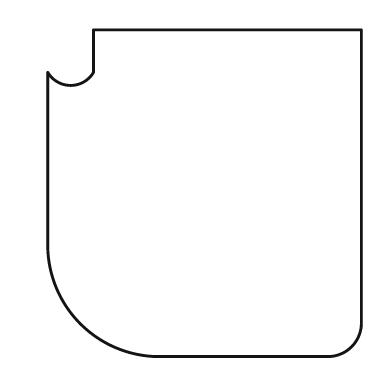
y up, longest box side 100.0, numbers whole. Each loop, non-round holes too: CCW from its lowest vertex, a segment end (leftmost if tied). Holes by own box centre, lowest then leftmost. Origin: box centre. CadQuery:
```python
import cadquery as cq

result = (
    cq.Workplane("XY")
    .moveTo(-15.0, -50.0)
    .lineTo(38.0, -50.0)
    .threePointArc((45.0, -47.0), (48.0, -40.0))
    .lineTo(48.0, 50.0)
    .lineTo(-34.0, 50.0)
    .lineTo(-34.0, 37.0)
    .threePointArc((-41.0, 33.0), (-48.0, 37.0))
    .lineTo(-48.0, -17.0)
    .threePointArc((-38.0, -40.0), (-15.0, -50.0))
    .close()
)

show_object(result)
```